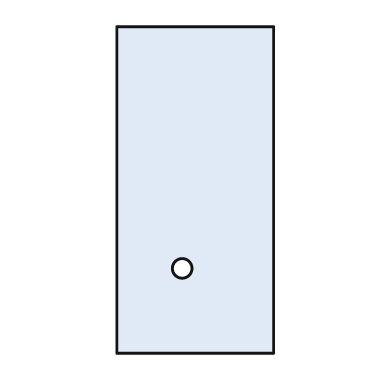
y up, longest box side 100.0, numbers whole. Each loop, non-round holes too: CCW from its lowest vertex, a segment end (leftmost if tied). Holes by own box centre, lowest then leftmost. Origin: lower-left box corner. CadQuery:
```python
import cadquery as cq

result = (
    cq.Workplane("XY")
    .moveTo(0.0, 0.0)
    .lineTo(48.0, 0.0)
    .lineTo(48.0, 100.0)
    .lineTo(0.0, 100.0)
    .close()
    .moveTo(20.0, 26.0)
    .circle(3.0)
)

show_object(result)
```